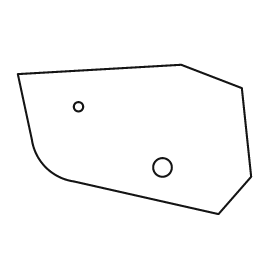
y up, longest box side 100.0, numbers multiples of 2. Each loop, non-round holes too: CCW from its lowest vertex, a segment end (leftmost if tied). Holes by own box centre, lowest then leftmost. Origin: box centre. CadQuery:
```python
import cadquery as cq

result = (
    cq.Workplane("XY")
    .moveTo(36.0, -32.0)
    .lineTo(50.0, -16.0)
    .lineTo(46.0, 22.0)
    .lineTo(20.0, 32.0)
    .lineTo(-50.0, 28.0)
    .lineTo(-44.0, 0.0)
    .threePointArc((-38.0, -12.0), (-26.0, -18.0))
    .close()
    .moveTo(12.0, -12.0)
    .circle(4.0)
    .moveTo(-24.0, 14.0)
    .circle(2.0)
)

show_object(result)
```